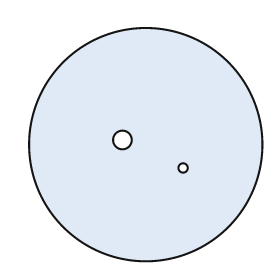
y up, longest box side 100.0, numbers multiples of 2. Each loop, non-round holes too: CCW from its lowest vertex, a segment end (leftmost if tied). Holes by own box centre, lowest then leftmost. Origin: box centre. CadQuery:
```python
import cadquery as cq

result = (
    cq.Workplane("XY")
    .moveTo(0.0, 0.0)
    .circle(50.0)
    .moveTo(16.0, -10.0)
    .circle(2.0)
    .moveTo(-10.0, 2.0)
    .circle(4.0)
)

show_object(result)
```